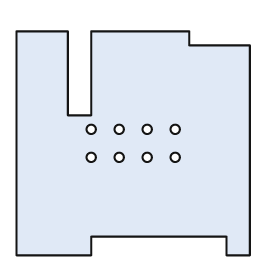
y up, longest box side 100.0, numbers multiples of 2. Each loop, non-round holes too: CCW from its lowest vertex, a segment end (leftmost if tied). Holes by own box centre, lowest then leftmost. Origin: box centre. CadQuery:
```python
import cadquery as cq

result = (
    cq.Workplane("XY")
    .moveTo(-50.0, -48.0)
    .lineTo(-18.0, -48.0)
    .lineTo(-18.0, -40.0)
    .lineTo(40.0, -40.0)
    .lineTo(40.0, -48.0)
    .lineTo(50.0, -48.0)
    .lineTo(50.0, 42.0)
    .lineTo(24.0, 42.0)
    .lineTo(24.0, 48.0)
    .lineTo(-18.0, 48.0)
    .lineTo(-18.0, 12.0)
    .lineTo(-28.0, 12.0)
    .lineTo(-28.0, 48.0)
    .lineTo(-50.0, 48.0)
    .close()
    .moveTo(-18.0, -6.0)
    .circle(2.0)
    .moveTo(-6.0, -6.0)
    .circle(2.0)
    .moveTo(6.0, -6.0)
    .circle(2.0)
    .moveTo(18.0, -6.0)
    .circle(2.0)
    .moveTo(-18.0, 6.0)
    .circle(2.0)
    .moveTo(-6.0, 6.0)
    .circle(2.0)
    .moveTo(6.0, 6.0)
    .circle(2.0)
    .moveTo(18.0, 6.0)
    .circle(2.0)
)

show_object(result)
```